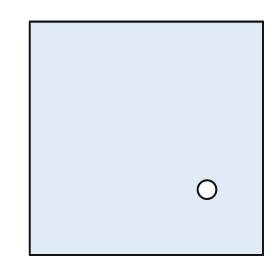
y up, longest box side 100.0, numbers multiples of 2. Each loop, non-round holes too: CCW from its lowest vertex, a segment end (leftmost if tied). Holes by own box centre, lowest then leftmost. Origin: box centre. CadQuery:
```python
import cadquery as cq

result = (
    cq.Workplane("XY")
    .moveTo(-50.0, -50.0)
    .lineTo(50.0, -50.0)
    .lineTo(50.0, 50.0)
    .lineTo(-50.0, 50.0)
    .close()
    .moveTo(26.0, -22.0)
    .circle(4.0)
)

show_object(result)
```